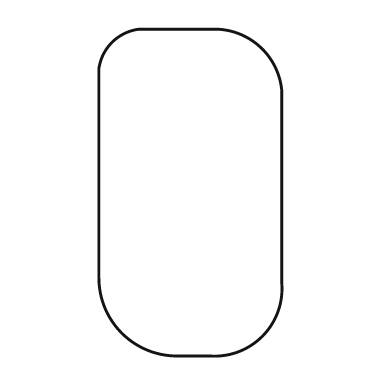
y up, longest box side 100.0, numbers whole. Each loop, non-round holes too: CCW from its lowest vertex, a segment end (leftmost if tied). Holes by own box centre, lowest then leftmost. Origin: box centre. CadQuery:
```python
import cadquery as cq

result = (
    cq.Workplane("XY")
    .moveTo(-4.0, -50.0)
    .lineTo(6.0, -50.0)
    .threePointArc((22.0, -44.0), (28.0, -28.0))
    .lineTo(28.0, 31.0)
    .threePointArc((22.0, 44.0), (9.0, 50.0))
    .lineTo(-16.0, 50.0)
    .threePointArc((-24.0, 46.0), (-28.0, 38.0))
    .lineTo(-28.0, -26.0)
    .threePointArc((-21.0, -43.0), (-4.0, -50.0))
    .close()
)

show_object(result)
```